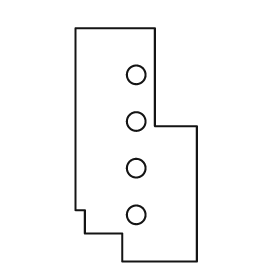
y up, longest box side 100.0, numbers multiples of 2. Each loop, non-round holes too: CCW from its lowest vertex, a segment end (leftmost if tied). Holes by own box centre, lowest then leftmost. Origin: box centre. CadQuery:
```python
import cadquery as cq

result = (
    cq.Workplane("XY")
    .moveTo(-6.0, -50.0)
    .lineTo(26.0, -50.0)
    .lineTo(26.0, 8.0)
    .lineTo(8.0, 8.0)
    .lineTo(8.0, 50.0)
    .lineTo(-26.0, 50.0)
    .lineTo(-26.0, -28.0)
    .lineTo(-22.0, -28.0)
    .lineTo(-22.0, -38.0)
    .lineTo(-6.0, -38.0)
    .close()
    .moveTo(0.0, -30.0)
    .circle(4.0)
    .moveTo(0.0, -10.0)
    .circle(4.0)
    .moveTo(0.0, 10.0)
    .circle(4.0)
    .moveTo(0.0, 30.0)
    .circle(4.0)
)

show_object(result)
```